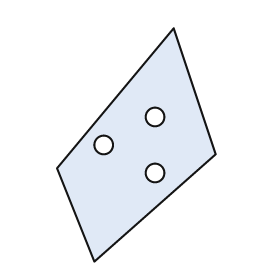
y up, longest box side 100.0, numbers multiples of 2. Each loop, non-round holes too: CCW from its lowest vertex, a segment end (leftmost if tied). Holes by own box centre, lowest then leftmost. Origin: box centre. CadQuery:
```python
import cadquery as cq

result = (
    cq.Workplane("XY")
    .moveTo(-18.0, -50.0)
    .lineTo(34.0, -4.0)
    .lineTo(16.0, 50.0)
    .lineTo(-34.0, -10.0)
    .close()
    .moveTo(8.0, -12.0)
    .circle(4.0)
    .moveTo(-14.0, 0.0)
    .circle(4.0)
    .moveTo(8.0, 12.0)
    .circle(4.0)
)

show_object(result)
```